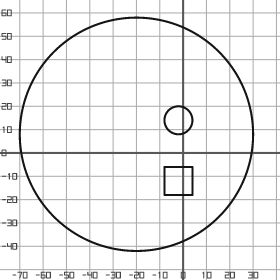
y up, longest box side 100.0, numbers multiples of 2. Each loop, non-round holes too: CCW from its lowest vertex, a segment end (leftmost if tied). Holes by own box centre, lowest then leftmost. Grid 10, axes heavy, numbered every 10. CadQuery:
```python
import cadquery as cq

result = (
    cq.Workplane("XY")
    .moveTo(-20.0, 8.0)
    .circle(50.0)
    .moveTo(-8.0, -18.0)
    .lineTo(4.0, -18.0)
    .lineTo(4.0, -6.0)
    .lineTo(-8.0, -6.0)
    .close()
    .moveTo(-2.0, 14.0)
    .circle(6.0)
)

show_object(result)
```